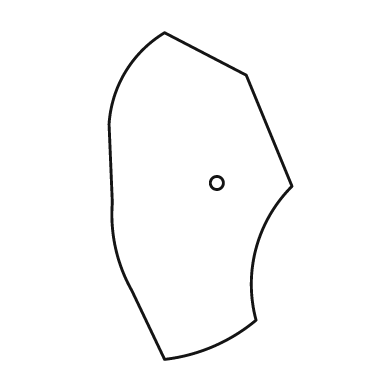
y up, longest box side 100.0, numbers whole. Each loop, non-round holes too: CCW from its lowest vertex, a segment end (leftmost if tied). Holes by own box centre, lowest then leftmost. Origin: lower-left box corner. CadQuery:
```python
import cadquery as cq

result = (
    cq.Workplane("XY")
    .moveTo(17.0, 0.0)
    .threePointArc((32.0, 4.0), (45.0, 12.0))
    .threePointArc((45.0, 34.0), (56.0, 53.0))
    .lineTo(42.0, 87.0)
    .lineTo(17.0, 100.0)
    .threePointArc((5.0, 88.0), (0.0, 72.0))
    .lineTo(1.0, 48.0)
    .threePointArc((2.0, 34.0), (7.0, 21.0))
    .close()
    .moveTo(33.0, 54.0)
    .circle(2.0)
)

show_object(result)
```